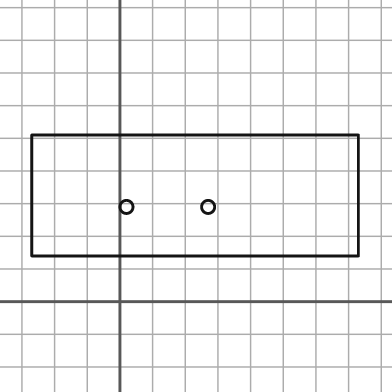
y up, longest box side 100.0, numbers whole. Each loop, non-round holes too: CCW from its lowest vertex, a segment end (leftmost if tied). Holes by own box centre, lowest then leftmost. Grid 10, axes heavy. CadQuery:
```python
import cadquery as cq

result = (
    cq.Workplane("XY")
    .moveTo(-27.0, 14.0)
    .lineTo(73.0, 14.0)
    .lineTo(73.0, 51.0)
    .lineTo(-27.0, 51.0)
    .close()
    .moveTo(2.0, 29.0)
    .circle(2.0)
    .moveTo(27.0, 29.0)
    .circle(2.0)
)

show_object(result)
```